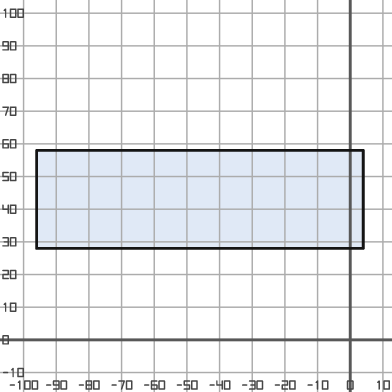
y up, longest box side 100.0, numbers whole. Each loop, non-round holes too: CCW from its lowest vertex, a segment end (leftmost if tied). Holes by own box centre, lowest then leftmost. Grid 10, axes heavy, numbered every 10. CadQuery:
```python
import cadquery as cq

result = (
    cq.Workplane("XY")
    .moveTo(-96.0, 28.0)
    .lineTo(4.0, 28.0)
    .lineTo(4.0, 58.0)
    .lineTo(-96.0, 58.0)
    .close()
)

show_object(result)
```